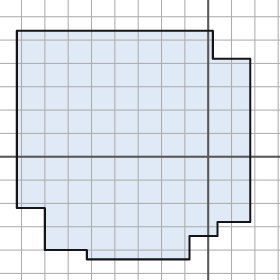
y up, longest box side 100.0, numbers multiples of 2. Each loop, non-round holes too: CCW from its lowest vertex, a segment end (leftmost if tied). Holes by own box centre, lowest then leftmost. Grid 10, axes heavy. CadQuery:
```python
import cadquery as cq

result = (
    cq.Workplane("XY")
    .moveTo(-52.0, -44.0)
    .lineTo(-8.0, -44.0)
    .lineTo(-8.0, -34.0)
    .lineTo(4.0, -34.0)
    .lineTo(4.0, -28.0)
    .lineTo(18.0, -28.0)
    .lineTo(18.0, 42.0)
    .lineTo(2.0, 42.0)
    .lineTo(2.0, 54.0)
    .lineTo(-82.0, 54.0)
    .lineTo(-82.0, -22.0)
    .lineTo(-70.0, -22.0)
    .lineTo(-70.0, -40.0)
    .lineTo(-52.0, -40.0)
    .close()
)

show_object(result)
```